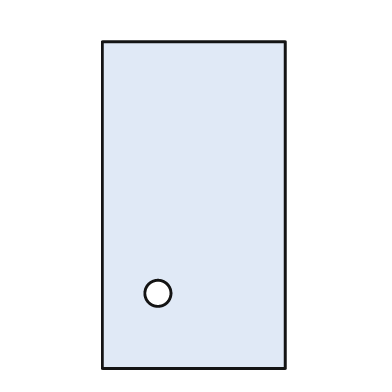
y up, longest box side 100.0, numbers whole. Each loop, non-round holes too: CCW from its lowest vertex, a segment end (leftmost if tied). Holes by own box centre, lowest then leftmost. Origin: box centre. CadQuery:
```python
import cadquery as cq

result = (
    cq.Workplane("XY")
    .moveTo(-28.0, -50.0)
    .lineTo(28.0, -50.0)
    .lineTo(28.0, 50.0)
    .lineTo(-28.0, 50.0)
    .close()
    .moveTo(-11.0, -27.0)
    .circle(4.0)
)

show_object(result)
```